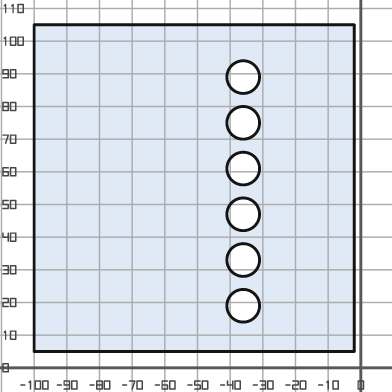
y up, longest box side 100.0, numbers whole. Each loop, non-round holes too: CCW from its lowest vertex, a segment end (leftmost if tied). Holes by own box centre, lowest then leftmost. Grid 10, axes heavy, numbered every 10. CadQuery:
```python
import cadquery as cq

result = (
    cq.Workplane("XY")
    .moveTo(-100.0, 5.0)
    .lineTo(-2.0, 5.0)
    .lineTo(-2.0, 105.0)
    .lineTo(-100.0, 105.0)
    .close()
    .moveTo(-36.0, 19.0)
    .circle(5.0)
    .moveTo(-36.0, 33.0)
    .circle(5.0)
    .moveTo(-36.0, 47.0)
    .circle(5.0)
    .moveTo(-36.0, 61.0)
    .circle(5.0)
    .moveTo(-36.0, 75.0)
    .circle(5.0)
    .moveTo(-36.0, 89.0)
    .circle(5.0)
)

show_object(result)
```